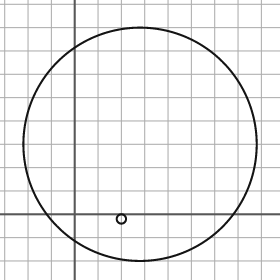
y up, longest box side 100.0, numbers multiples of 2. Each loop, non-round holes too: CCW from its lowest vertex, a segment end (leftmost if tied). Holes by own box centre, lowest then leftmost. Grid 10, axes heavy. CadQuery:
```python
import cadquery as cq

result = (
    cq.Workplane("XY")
    .moveTo(28.0, 30.0)
    .circle(50.0)
    .moveTo(20.0, -2.0)
    .circle(2.0)
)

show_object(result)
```